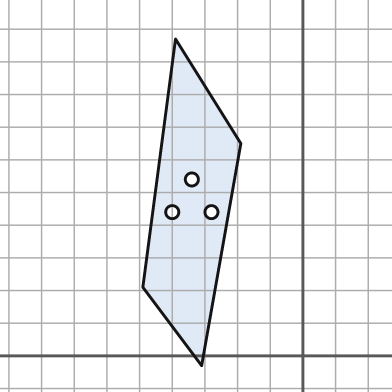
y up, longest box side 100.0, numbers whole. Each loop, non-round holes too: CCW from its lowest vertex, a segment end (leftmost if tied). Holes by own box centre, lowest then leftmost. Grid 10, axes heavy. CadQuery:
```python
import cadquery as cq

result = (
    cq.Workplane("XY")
    .moveTo(-31.0, -3.0)
    .lineTo(-19.0, 65.0)
    .lineTo(-39.0, 97.0)
    .lineTo(-49.0, 21.0)
    .close()
    .moveTo(-40.0, 44.0)
    .circle(2.0)
    .moveTo(-28.0, 44.0)
    .circle(2.0)
    .moveTo(-34.0, 54.0)
    .circle(2.0)
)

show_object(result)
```